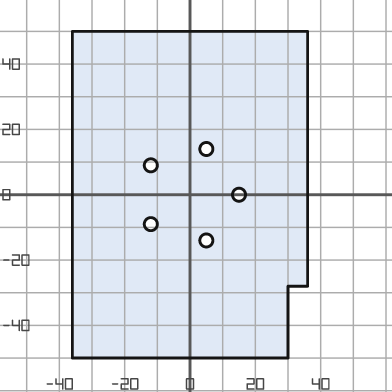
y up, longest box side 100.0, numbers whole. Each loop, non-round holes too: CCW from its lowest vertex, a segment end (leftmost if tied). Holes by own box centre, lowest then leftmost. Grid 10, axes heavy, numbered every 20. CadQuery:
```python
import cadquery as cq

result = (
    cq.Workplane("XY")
    .moveTo(-36.0, -50.0)
    .lineTo(30.0, -50.0)
    .lineTo(30.0, -28.0)
    .lineTo(36.0, -28.0)
    .lineTo(36.0, 50.0)
    .lineTo(-36.0, 50.0)
    .close()
    .moveTo(5.0, -14.0)
    .circle(2.0)
    .moveTo(-12.0, -9.0)
    .circle(2.0)
    .moveTo(15.0, 0.0)
    .circle(2.0)
    .moveTo(-12.0, 9.0)
    .circle(2.0)
    .moveTo(5.0, 14.0)
    .circle(2.0)
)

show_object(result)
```